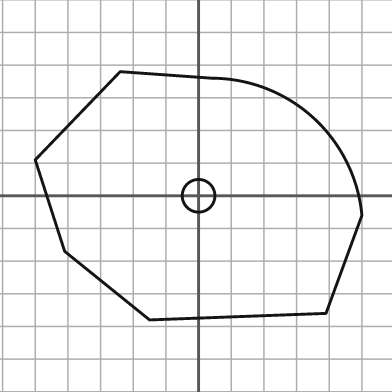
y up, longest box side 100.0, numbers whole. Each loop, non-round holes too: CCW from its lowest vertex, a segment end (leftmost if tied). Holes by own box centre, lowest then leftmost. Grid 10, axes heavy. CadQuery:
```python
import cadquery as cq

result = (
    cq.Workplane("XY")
    .moveTo(-15.0, -38.0)
    .lineTo(39.0, -36.0)
    .lineTo(50.0, -6.0)
    .threePointArc((35.0, 24.0), (4.0, 36.0))
    .lineTo(-24.0, 38.0)
    .lineTo(-50.0, 11.0)
    .lineTo(-41.0, -17.0)
    .close()
    .moveTo(0.0, 0.0)
    .circle(5.0)
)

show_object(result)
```